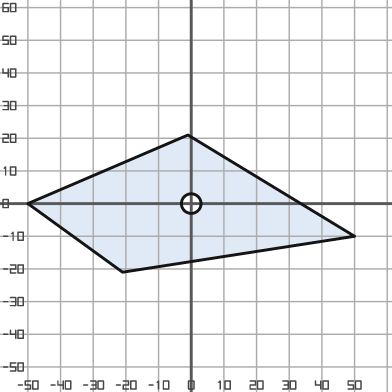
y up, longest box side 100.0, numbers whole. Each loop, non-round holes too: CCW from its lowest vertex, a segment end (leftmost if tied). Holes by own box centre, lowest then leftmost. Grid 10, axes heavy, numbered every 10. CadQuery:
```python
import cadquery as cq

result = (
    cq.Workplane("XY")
    .moveTo(-21.0, -21.0)
    .lineTo(50.0, -10.0)
    .lineTo(-1.0, 21.0)
    .lineTo(-50.0, 0.0)
    .close()
    .moveTo(0.0, 0.0)
    .circle(3.0)
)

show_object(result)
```